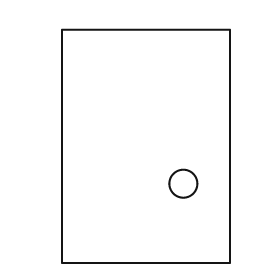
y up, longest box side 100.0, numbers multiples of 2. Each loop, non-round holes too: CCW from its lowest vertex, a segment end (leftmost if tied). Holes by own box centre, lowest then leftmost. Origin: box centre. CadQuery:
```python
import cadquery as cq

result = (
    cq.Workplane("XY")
    .moveTo(-36.0, -50.0)
    .lineTo(36.0, -50.0)
    .lineTo(36.0, 50.0)
    .lineTo(-36.0, 50.0)
    .close()
    .moveTo(16.0, -16.0)
    .circle(6.0)
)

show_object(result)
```